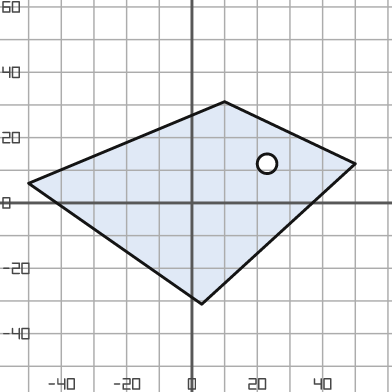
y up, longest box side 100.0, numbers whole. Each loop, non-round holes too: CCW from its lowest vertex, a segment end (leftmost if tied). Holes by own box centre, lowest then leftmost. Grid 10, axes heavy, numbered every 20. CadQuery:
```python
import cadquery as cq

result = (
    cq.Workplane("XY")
    .moveTo(3.0, -31.0)
    .lineTo(50.0, 12.0)
    .lineTo(10.0, 31.0)
    .lineTo(-50.0, 6.0)
    .close()
    .moveTo(23.0, 12.0)
    .circle(3.0)
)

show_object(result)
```